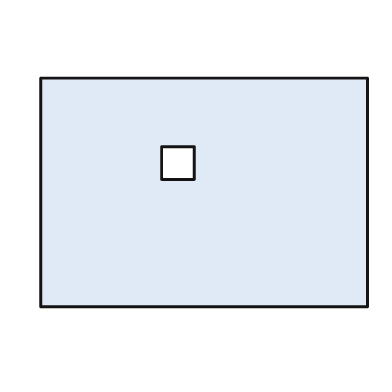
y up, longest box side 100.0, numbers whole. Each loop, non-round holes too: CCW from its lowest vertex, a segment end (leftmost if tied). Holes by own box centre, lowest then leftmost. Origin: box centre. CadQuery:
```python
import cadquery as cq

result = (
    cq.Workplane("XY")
    .moveTo(-50.0, -35.0)
    .lineTo(50.0, -35.0)
    .lineTo(50.0, 35.0)
    .lineTo(-50.0, 35.0)
    .close()
    .moveTo(-13.0, 4.0)
    .lineTo(-3.0, 4.0)
    .lineTo(-3.0, 14.0)
    .lineTo(-13.0, 14.0)
    .close()
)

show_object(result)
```